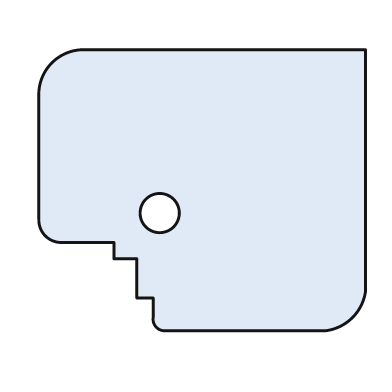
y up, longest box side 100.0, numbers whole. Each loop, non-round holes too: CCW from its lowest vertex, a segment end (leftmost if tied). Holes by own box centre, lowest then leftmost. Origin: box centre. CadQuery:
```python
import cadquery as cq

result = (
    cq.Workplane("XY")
    .moveTo(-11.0, -43.0)
    .lineTo(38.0, -43.0)
    .threePointArc((46.0, -39.0), (50.0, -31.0))
    .lineTo(50.0, 43.0)
    .lineTo(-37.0, 43.0)
    .threePointArc((-46.0, 39.0), (-50.0, 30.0))
    .lineTo(-50.0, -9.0)
    .threePointArc((-48.0, -14.0), (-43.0, -16.0))
    .lineTo(-27.0, -16.0)
    .lineTo(-27.0, -21.0)
    .lineTo(-20.0, -21.0)
    .lineTo(-20.0, -33.0)
    .lineTo(-15.0, -33.0)
    .lineTo(-15.0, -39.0)
    .threePointArc((-14.0, -42.0), (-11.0, -43.0))
    .close()
    .moveTo(-13.0, -7.0)
    .circle(6.0)
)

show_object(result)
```